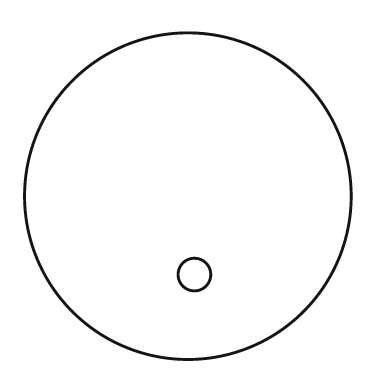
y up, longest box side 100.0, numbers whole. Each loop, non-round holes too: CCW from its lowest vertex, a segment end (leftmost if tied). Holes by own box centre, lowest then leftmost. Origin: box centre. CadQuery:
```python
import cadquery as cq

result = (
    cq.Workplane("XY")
    .moveTo(0.0, 0.0)
    .circle(50.0)
    .moveTo(2.0, -24.0)
    .circle(5.0)
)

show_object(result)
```